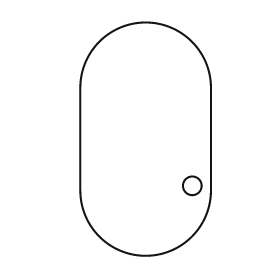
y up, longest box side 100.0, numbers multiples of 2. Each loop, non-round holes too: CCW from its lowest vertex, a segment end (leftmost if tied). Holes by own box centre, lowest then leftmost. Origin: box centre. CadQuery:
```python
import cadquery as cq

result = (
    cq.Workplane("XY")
    .moveTo(-28.0, -22.0)
    .threePointArc((0.0, -50.0), (28.0, -22.0))
    .lineTo(28.0, 22.0)
    .threePointArc((0.0, 50.0), (-28.0, 22.0))
    .close()
    .moveTo(20.0, -20.0)
    .circle(4.0)
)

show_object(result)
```